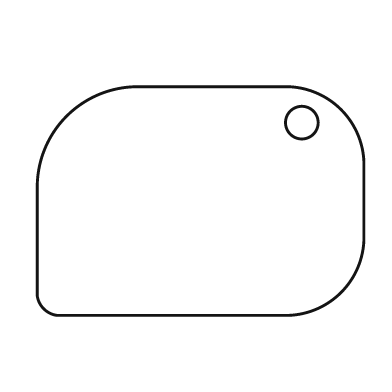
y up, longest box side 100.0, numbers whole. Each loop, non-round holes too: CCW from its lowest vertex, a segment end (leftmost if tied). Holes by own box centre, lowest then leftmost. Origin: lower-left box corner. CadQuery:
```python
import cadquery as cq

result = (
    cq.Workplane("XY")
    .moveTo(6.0, 0.0)
    .lineTo(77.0, 0.0)
    .threePointArc((93.0, 7.0), (100.0, 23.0))
    .lineTo(100.0, 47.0)
    .threePointArc((93.0, 63.0), (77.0, 70.0))
    .lineTo(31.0, 70.0)
    .threePointArc((9.0, 61.0), (0.0, 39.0))
    .lineTo(0.0, 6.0)
    .threePointArc((2.0, 2.0), (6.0, 0.0))
    .close()
    .moveTo(81.0, 59.0)
    .circle(5.0)
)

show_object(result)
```